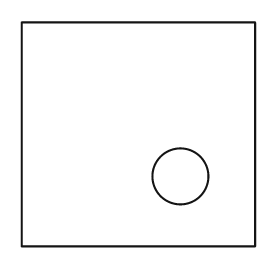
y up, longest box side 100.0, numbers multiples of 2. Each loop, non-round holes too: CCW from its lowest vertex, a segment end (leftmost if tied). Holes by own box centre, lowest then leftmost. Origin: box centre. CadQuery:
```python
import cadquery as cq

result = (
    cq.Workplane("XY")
    .moveTo(-50.0, -48.0)
    .lineTo(50.0, -48.0)
    .lineTo(50.0, 48.0)
    .lineTo(-50.0, 48.0)
    .close()
    .moveTo(18.0, -18.0)
    .circle(12.0)
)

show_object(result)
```